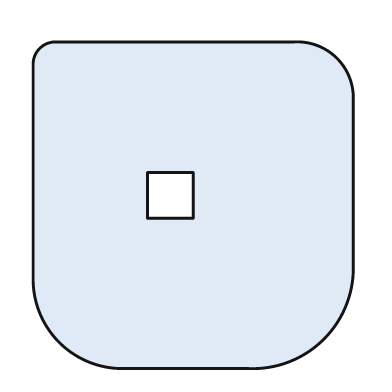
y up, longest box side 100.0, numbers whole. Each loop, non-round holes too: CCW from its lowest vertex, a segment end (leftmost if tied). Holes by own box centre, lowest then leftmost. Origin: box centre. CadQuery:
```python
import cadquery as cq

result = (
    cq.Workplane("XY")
    .moveTo(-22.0, -50.0)
    .lineTo(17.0, -50.0)
    .threePointArc((40.0, -41.0), (49.0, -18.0))
    .lineTo(49.0, 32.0)
    .threePointArc((44.0, 45.0), (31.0, 50.0))
    .lineTo(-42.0, 50.0)
    .threePointArc((-47.0, 48.0), (-49.0, 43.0))
    .lineTo(-49.0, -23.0)
    .threePointArc((-41.0, -42.0), (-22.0, -50.0))
    .close()
    .moveTo(-14.0, -4.0)
    .lineTo(0.0, -4.0)
    .lineTo(0.0, 10.0)
    .lineTo(-14.0, 10.0)
    .close()
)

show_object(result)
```